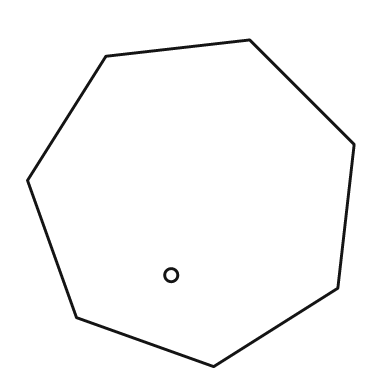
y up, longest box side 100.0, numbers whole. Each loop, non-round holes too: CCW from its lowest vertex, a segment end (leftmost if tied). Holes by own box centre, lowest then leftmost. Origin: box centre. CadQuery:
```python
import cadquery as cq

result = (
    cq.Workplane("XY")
    .moveTo(7.0, -50.0)
    .lineTo(45.0, -26.0)
    .lineTo(50.0, 18.0)
    .lineTo(18.0, 50.0)
    .lineTo(-26.0, 45.0)
    .lineTo(-50.0, 7.0)
    .lineTo(-35.0, -35.0)
    .close()
    .moveTo(-6.0, -22.0)
    .circle(2.0)
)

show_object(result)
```